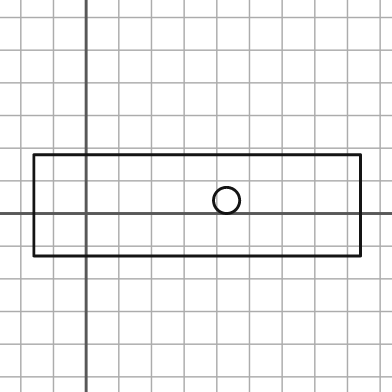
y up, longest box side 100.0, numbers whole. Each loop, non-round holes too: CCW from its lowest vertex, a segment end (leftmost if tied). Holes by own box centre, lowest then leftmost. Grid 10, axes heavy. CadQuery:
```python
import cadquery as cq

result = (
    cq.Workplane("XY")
    .moveTo(-16.0, -13.0)
    .lineTo(84.0, -13.0)
    .lineTo(84.0, 18.0)
    .lineTo(-16.0, 18.0)
    .close()
    .moveTo(43.0, 4.0)
    .circle(4.0)
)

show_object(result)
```